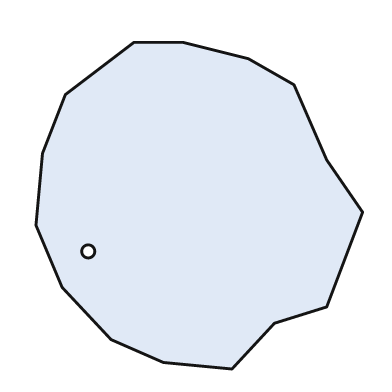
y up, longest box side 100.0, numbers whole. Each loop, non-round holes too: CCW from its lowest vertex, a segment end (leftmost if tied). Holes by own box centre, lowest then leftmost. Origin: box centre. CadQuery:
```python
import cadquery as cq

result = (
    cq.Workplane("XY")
    .moveTo(10.0, -50.0)
    .lineTo(23.0, -36.0)
    .lineTo(39.0, -31.0)
    .lineTo(50.0, -2.0)
    .lineTo(39.0, 14.0)
    .lineTo(29.0, 37.0)
    .lineTo(15.0, 45.0)
    .lineTo(-5.0, 50.0)
    .lineTo(-20.0, 50.0)
    .lineTo(-41.0, 34.0)
    .lineTo(-48.0, 16.0)
    .lineTo(-50.0, -6.0)
    .lineTo(-42.0, -25.0)
    .lineTo(-27.0, -41.0)
    .lineTo(-11.0, -48.0)
    .close()
    .moveTo(-34.0, -14.0)
    .circle(2.0)
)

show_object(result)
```